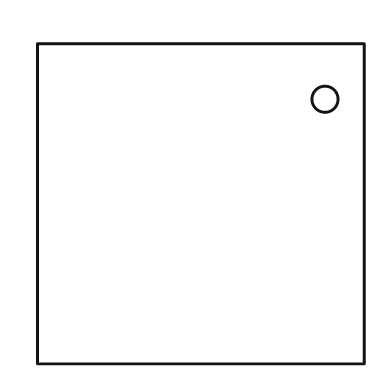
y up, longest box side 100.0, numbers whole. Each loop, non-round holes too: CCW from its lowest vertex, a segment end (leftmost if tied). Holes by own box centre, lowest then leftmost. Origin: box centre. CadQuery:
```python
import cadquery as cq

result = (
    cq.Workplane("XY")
    .moveTo(-50.0, -49.0)
    .lineTo(50.0, -49.0)
    .lineTo(50.0, 49.0)
    .lineTo(-50.0, 49.0)
    .close()
    .moveTo(38.0, 32.0)
    .circle(4.0)
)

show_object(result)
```